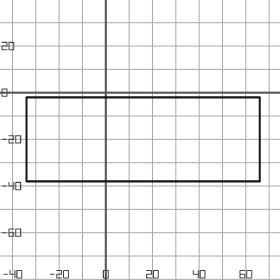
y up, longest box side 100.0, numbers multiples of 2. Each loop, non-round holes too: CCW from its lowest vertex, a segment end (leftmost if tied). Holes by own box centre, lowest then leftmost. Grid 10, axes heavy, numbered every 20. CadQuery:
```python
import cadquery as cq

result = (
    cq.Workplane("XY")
    .moveTo(-34.0, -38.0)
    .lineTo(66.0, -38.0)
    .lineTo(66.0, -2.0)
    .lineTo(-34.0, -2.0)
    .close()
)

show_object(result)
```